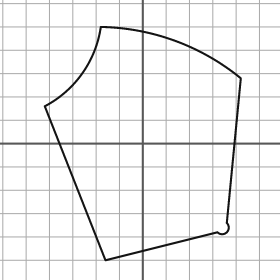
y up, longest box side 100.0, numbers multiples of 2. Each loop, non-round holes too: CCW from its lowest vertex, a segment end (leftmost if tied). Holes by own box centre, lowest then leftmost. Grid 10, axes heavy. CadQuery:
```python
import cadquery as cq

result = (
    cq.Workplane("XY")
    .moveTo(-16.0, -50.0)
    .lineTo(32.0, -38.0)
    .threePointArc((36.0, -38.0), (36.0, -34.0))
    .lineTo(42.0, 28.0)
    .threePointArc((14.0, 44.0), (-18.0, 50.0))
    .threePointArc((-26.0, 30.0), (-42.0, 16.0))
    .close()
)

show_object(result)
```